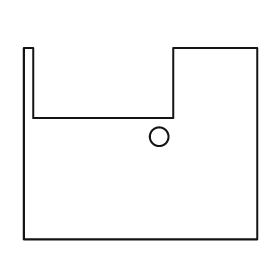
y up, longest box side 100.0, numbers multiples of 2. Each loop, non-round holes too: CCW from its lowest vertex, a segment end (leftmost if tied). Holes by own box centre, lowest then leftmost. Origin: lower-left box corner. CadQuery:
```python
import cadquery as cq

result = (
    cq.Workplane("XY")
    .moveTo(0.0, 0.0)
    .lineTo(100.0, 0.0)
    .lineTo(100.0, 82.0)
    .lineTo(64.0, 82.0)
    .lineTo(64.0, 52.0)
    .lineTo(4.0, 52.0)
    .lineTo(4.0, 82.0)
    .lineTo(0.0, 82.0)
    .close()
    .moveTo(58.0, 44.0)
    .circle(4.0)
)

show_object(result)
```